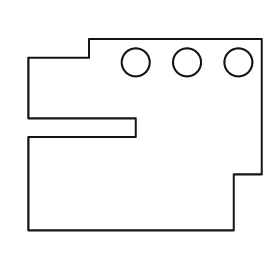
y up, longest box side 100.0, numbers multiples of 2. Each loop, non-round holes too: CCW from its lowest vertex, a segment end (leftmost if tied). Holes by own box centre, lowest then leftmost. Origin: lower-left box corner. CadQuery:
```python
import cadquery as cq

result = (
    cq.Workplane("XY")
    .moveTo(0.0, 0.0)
    .lineTo(88.0, 0.0)
    .lineTo(88.0, 24.0)
    .lineTo(100.0, 24.0)
    .lineTo(100.0, 82.0)
    .lineTo(26.0, 82.0)
    .lineTo(26.0, 74.0)
    .lineTo(0.0, 74.0)
    .lineTo(0.0, 48.0)
    .lineTo(46.0, 48.0)
    .lineTo(46.0, 40.0)
    .lineTo(0.0, 40.0)
    .close()
    .moveTo(46.0, 72.0)
    .circle(6.0)
    .moveTo(68.0, 72.0)
    .circle(6.0)
    .moveTo(90.0, 72.0)
    .circle(6.0)
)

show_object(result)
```